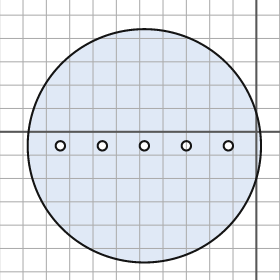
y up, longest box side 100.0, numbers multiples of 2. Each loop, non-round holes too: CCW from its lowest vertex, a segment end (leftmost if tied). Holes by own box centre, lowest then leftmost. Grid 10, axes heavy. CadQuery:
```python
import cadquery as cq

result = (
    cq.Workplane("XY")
    .moveTo(-48.0, -6.0)
    .circle(50.0)
    .moveTo(-84.0, -6.0)
    .circle(2.0)
    .moveTo(-66.0, -6.0)
    .circle(2.0)
    .moveTo(-48.0, -6.0)
    .circle(2.0)
    .moveTo(-30.0, -6.0)
    .circle(2.0)
    .moveTo(-12.0, -6.0)
    .circle(2.0)
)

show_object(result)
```